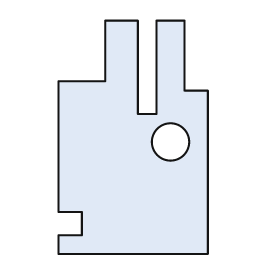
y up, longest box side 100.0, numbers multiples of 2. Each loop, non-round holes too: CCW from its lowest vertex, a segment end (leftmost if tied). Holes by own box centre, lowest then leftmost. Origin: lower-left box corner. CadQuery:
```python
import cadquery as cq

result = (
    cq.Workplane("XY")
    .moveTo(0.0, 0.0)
    .lineTo(64.0, 0.0)
    .lineTo(64.0, 70.0)
    .lineTo(54.0, 70.0)
    .lineTo(54.0, 100.0)
    .lineTo(42.0, 100.0)
    .lineTo(42.0, 60.0)
    .lineTo(34.0, 60.0)
    .lineTo(34.0, 100.0)
    .lineTo(20.0, 100.0)
    .lineTo(20.0, 74.0)
    .lineTo(0.0, 74.0)
    .lineTo(0.0, 18.0)
    .lineTo(10.0, 18.0)
    .lineTo(10.0, 8.0)
    .lineTo(0.0, 8.0)
    .close()
    .moveTo(48.0, 48.0)
    .circle(8.0)
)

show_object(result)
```